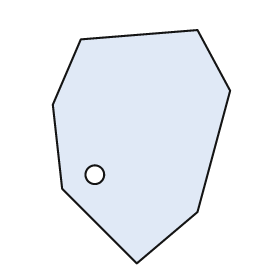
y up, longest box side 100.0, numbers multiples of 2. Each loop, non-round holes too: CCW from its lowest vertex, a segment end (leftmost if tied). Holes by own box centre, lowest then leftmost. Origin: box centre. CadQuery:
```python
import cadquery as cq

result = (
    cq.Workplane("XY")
    .moveTo(-2.0, -50.0)
    .lineTo(24.0, -28.0)
    .lineTo(38.0, 24.0)
    .lineTo(24.0, 50.0)
    .lineTo(-26.0, 46.0)
    .lineTo(-38.0, 18.0)
    .lineTo(-34.0, -18.0)
    .close()
    .moveTo(-20.0, -12.0)
    .circle(4.0)
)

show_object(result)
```